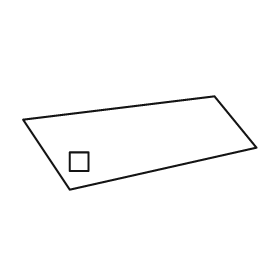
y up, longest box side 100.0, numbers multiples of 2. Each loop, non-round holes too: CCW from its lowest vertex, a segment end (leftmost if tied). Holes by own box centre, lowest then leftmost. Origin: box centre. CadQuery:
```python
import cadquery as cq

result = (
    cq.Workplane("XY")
    .moveTo(-30.0, -20.0)
    .lineTo(50.0, -2.0)
    .lineTo(32.0, 20.0)
    .lineTo(-50.0, 10.0)
    .close()
    .moveTo(-30.0, -12.0)
    .lineTo(-22.0, -12.0)
    .lineTo(-22.0, -4.0)
    .lineTo(-30.0, -4.0)
    .close()
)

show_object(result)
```